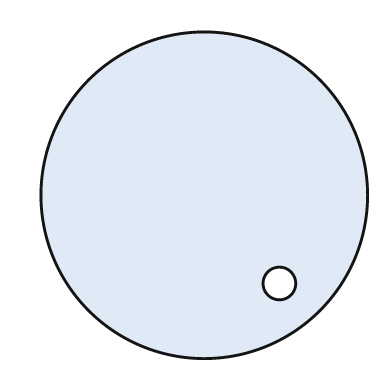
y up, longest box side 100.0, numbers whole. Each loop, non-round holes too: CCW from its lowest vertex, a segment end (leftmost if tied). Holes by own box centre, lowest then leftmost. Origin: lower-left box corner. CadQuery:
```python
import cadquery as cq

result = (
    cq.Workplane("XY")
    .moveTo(50.0, 50.0)
    .circle(50.0)
    .moveTo(73.0, 23.0)
    .circle(5.0)
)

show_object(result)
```